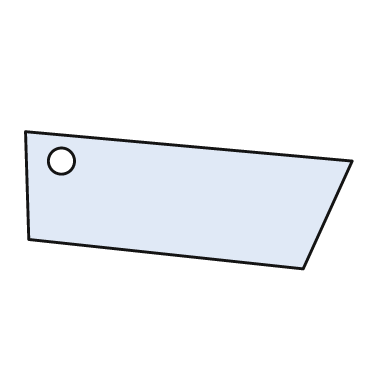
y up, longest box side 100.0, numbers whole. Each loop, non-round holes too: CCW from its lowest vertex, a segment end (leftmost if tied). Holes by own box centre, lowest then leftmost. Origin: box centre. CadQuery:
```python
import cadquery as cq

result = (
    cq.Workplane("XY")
    .moveTo(35.0, -21.0)
    .lineTo(50.0, 12.0)
    .lineTo(-50.0, 21.0)
    .lineTo(-49.0, -12.0)
    .close()
    .moveTo(-39.0, 12.0)
    .circle(4.0)
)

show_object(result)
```